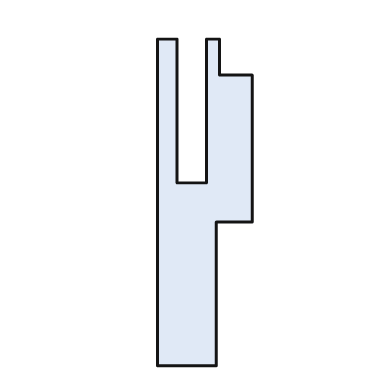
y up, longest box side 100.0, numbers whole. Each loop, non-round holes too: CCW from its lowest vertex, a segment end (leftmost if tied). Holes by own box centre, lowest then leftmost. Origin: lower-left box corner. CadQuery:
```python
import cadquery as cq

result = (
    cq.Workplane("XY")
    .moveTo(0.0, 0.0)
    .lineTo(18.0, 0.0)
    .lineTo(18.0, 44.0)
    .lineTo(29.0, 44.0)
    .lineTo(29.0, 89.0)
    .lineTo(19.0, 89.0)
    .lineTo(19.0, 100.0)
    .lineTo(15.0, 100.0)
    .lineTo(15.0, 56.0)
    .lineTo(6.0, 56.0)
    .lineTo(6.0, 100.0)
    .lineTo(0.0, 100.0)
    .close()
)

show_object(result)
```